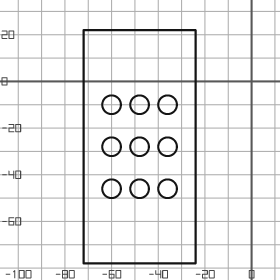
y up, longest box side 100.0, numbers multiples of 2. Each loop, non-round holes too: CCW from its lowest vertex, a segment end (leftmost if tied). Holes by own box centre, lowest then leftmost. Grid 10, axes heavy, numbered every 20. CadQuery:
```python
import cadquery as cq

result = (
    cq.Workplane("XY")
    .moveTo(-72.0, -78.0)
    .lineTo(-24.0, -78.0)
    .lineTo(-24.0, 22.0)
    .lineTo(-72.0, 22.0)
    .close()
    .moveTo(-60.0, -46.0)
    .circle(4.0)
    .moveTo(-48.0, -46.0)
    .circle(4.0)
    .moveTo(-36.0, -46.0)
    .circle(4.0)
    .moveTo(-60.0, -28.0)
    .circle(4.0)
    .moveTo(-48.0, -28.0)
    .circle(4.0)
    .moveTo(-36.0, -28.0)
    .circle(4.0)
    .moveTo(-60.0, -10.0)
    .circle(4.0)
    .moveTo(-48.0, -10.0)
    .circle(4.0)
    .moveTo(-36.0, -10.0)
    .circle(4.0)
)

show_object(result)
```